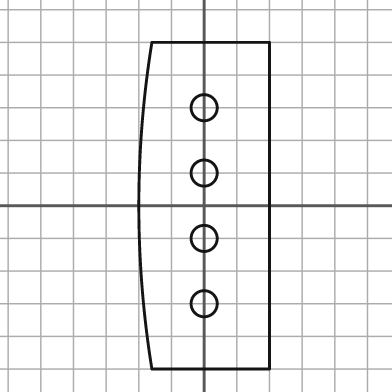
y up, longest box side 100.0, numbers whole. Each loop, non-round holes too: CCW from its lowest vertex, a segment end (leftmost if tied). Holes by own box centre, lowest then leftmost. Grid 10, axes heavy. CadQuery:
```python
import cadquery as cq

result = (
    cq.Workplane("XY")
    .moveTo(-16.0, -50.0)
    .lineTo(20.0, -50.0)
    .lineTo(20.0, 50.0)
    .lineTo(-16.0, 50.0)
    .threePointArc((-20.0, 0.0), (-16.0, -50.0))
    .close()
    .moveTo(0.0, -30.0)
    .circle(4.0)
    .moveTo(0.0, -10.0)
    .circle(4.0)
    .moveTo(0.0, 10.0)
    .circle(4.0)
    .moveTo(0.0, 30.0)
    .circle(4.0)
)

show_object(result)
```